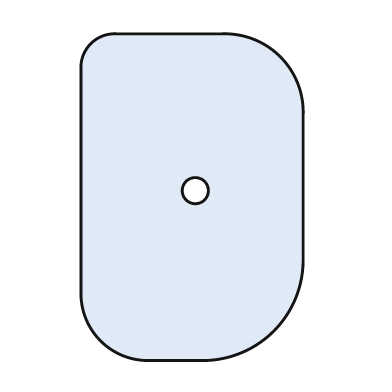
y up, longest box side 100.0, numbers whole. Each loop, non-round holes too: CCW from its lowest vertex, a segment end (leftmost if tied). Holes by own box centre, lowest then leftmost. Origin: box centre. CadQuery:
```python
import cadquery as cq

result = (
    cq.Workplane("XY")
    .moveTo(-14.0, -50.0)
    .lineTo(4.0, -50.0)
    .threePointArc((25.0, -41.0), (34.0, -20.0))
    .lineTo(34.0, 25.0)
    .threePointArc((27.0, 43.0), (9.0, 50.0))
    .lineTo(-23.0, 50.0)
    .threePointArc((-31.0, 47.0), (-34.0, 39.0))
    .lineTo(-34.0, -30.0)
    .threePointArc((-28.0, -44.0), (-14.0, -50.0))
    .close()
    .moveTo(1.0, 2.0)
    .circle(4.0)
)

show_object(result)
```